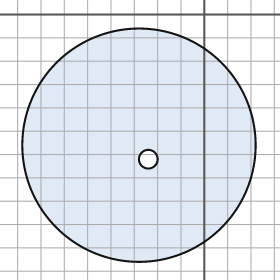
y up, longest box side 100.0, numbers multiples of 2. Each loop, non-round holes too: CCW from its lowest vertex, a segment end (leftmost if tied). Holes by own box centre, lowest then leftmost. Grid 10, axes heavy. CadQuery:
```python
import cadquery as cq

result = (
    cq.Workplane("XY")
    .moveTo(-28.0, -56.0)
    .circle(50.0)
    .moveTo(-24.0, -62.0)
    .circle(4.0)
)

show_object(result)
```